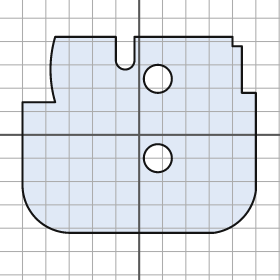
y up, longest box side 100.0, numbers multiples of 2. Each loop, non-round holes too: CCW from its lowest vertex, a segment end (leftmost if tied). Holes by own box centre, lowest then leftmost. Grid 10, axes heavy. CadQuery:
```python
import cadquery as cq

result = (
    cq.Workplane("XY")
    .moveTo(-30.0, -42.0)
    .lineTo(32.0, -42.0)
    .threePointArc((44.0, -36.0), (50.0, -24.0))
    .lineTo(50.0, 18.0)
    .lineTo(44.0, 18.0)
    .lineTo(44.0, 38.0)
    .lineTo(40.0, 38.0)
    .lineTo(40.0, 42.0)
    .lineTo(-2.0, 42.0)
    .lineTo(-2.0, 32.0)
    .threePointArc((-6.0, 28.0), (-10.0, 32.0))
    .lineTo(-10.0, 42.0)
    .lineTo(-36.0, 42.0)
    .threePointArc((-38.0, 28.0), (-36.0, 14.0))
    .lineTo(-50.0, 14.0)
    .lineTo(-50.0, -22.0)
    .threePointArc((-44.0, -36.0), (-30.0, -42.0))
    .close()
    .moveTo(8.0, -10.0)
    .circle(6.0)
    .moveTo(8.0, 24.0)
    .circle(6.0)
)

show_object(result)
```